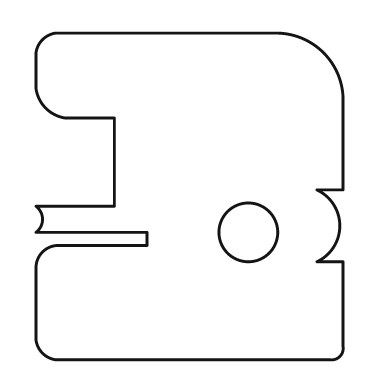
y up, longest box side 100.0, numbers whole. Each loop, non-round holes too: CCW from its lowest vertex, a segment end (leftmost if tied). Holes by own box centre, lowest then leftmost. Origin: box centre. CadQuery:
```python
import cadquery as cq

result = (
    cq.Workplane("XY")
    .moveTo(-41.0, -50.0)
    .lineTo(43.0, -50.0)
    .threePointArc((46.0, -49.0), (47.0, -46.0))
    .lineTo(47.0, -20.0)
    .lineTo(39.0, -20.0)
    .threePointArc((46.0, -9.0), (39.0, 2.0))
    .lineTo(47.0, 2.0)
    .lineTo(47.0, 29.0)
    .threePointArc((41.0, 44.0), (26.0, 50.0))
    .lineTo(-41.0, 50.0)
    .threePointArc((-45.0, 48.0), (-47.0, 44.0))
    .lineTo(-47.0, 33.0)
    .threePointArc((-44.0, 27.0), (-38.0, 24.0))
    .lineTo(-23.0, 24.0)
    .lineTo(-23.0, -3.0)
    .lineTo(-47.0, -3.0)
    .threePointArc((-45.0, -7.0), (-47.0, -11.0))
    .lineTo(-13.0, -11.0)
    .lineTo(-13.0, -15.0)
    .lineTo(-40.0, -15.0)
    .threePointArc((-45.0, -17.0), (-47.0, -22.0))
    .lineTo(-47.0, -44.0)
    .threePointArc((-45.0, -48.0), (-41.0, -50.0))
    .close()
    .moveTo(18.0, -11.0)
    .circle(9.0)
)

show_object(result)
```